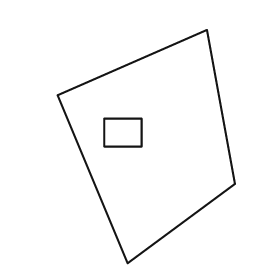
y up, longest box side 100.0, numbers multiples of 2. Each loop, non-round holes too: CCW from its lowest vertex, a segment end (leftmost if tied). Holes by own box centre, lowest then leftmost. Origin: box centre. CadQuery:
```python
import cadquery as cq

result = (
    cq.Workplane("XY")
    .moveTo(-8.0, -50.0)
    .lineTo(38.0, -16.0)
    .lineTo(26.0, 50.0)
    .lineTo(-38.0, 22.0)
    .close()
    .moveTo(-18.0, 0.0)
    .lineTo(-2.0, 0.0)
    .lineTo(-2.0, 12.0)
    .lineTo(-18.0, 12.0)
    .close()
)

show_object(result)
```